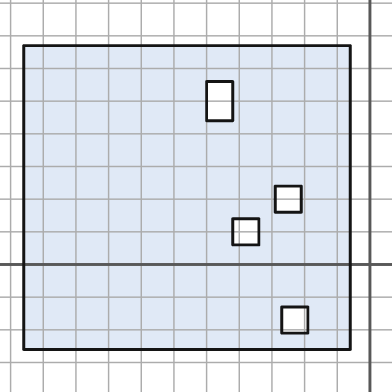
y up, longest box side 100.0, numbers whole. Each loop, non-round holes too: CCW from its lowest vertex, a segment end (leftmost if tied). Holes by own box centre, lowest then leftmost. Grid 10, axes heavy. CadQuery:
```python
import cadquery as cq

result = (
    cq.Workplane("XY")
    .moveTo(-106.0, -26.0)
    .lineTo(-6.0, -26.0)
    .lineTo(-6.0, 67.0)
    .lineTo(-106.0, 67.0)
    .close()
    .moveTo(-27.0, -21.0)
    .lineTo(-19.0, -21.0)
    .lineTo(-19.0, -13.0)
    .lineTo(-27.0, -13.0)
    .close()
    .moveTo(-42.0, 6.0)
    .lineTo(-34.0, 6.0)
    .lineTo(-34.0, 14.0)
    .lineTo(-42.0, 14.0)
    .close()
    .moveTo(-29.0, 16.0)
    .lineTo(-21.0, 16.0)
    .lineTo(-21.0, 24.0)
    .lineTo(-29.0, 24.0)
    .close()
    .moveTo(-50.0, 44.0)
    .lineTo(-42.0, 44.0)
    .lineTo(-42.0, 56.0)
    .lineTo(-50.0, 56.0)
    .close()
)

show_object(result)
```